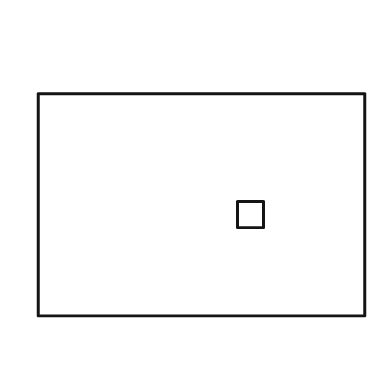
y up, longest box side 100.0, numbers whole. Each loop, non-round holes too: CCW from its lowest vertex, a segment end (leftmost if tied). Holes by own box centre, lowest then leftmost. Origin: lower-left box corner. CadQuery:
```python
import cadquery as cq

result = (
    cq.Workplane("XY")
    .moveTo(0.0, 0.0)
    .lineTo(100.0, 0.0)
    .lineTo(100.0, 68.0)
    .lineTo(0.0, 68.0)
    .close()
    .moveTo(61.0, 27.0)
    .lineTo(69.0, 27.0)
    .lineTo(69.0, 35.0)
    .lineTo(61.0, 35.0)
    .close()
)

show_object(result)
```